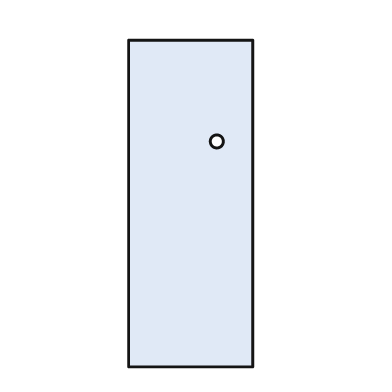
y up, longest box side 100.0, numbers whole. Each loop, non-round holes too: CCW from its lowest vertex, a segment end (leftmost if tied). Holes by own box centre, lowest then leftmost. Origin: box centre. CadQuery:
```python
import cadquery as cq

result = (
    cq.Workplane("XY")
    .moveTo(-19.0, -50.0)
    .lineTo(19.0, -50.0)
    .lineTo(19.0, 50.0)
    .lineTo(-19.0, 50.0)
    .close()
    .moveTo(8.0, 19.0)
    .circle(2.0)
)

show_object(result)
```